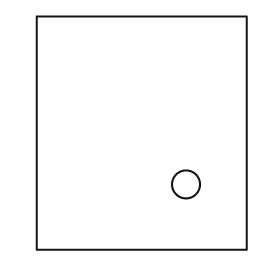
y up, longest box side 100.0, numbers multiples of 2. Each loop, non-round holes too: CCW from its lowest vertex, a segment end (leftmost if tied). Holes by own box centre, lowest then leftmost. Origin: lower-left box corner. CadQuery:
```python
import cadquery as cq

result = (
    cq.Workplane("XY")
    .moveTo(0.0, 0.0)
    .lineTo(90.0, 0.0)
    .lineTo(90.0, 100.0)
    .lineTo(0.0, 100.0)
    .close()
    .moveTo(64.0, 28.0)
    .circle(6.0)
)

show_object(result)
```